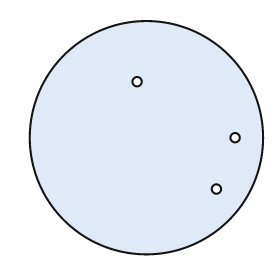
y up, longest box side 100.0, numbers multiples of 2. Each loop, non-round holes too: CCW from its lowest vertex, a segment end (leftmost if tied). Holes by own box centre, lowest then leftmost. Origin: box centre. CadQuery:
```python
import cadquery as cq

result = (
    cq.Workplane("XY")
    .moveTo(0.0, 0.0)
    .circle(50.0)
    .moveTo(30.0, -22.0)
    .circle(2.0)
    .moveTo(38.0, 0.0)
    .circle(2.0)
    .moveTo(-4.0, 24.0)
    .circle(2.0)
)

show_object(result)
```